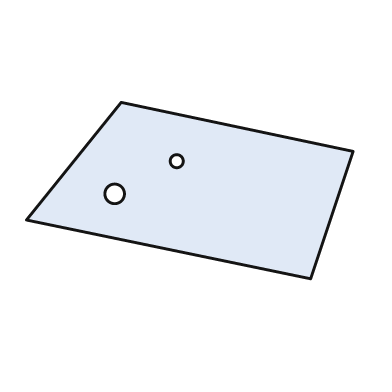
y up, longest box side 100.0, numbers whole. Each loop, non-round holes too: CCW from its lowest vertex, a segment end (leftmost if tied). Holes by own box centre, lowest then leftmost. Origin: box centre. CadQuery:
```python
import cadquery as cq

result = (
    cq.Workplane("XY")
    .moveTo(37.0, -27.0)
    .lineTo(50.0, 12.0)
    .lineTo(-21.0, 27.0)
    .lineTo(-50.0, -9.0)
    .close()
    .moveTo(-23.0, -1.0)
    .circle(3.0)
    .moveTo(-4.0, 9.0)
    .circle(2.0)
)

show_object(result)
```